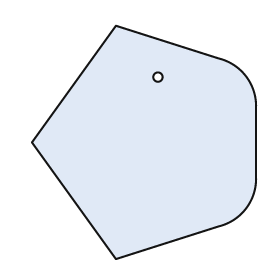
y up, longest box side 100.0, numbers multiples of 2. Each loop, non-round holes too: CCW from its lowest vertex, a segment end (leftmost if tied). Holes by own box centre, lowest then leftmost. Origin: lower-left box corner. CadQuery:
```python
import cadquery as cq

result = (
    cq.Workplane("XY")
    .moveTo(36.0, 0.0)
    .lineTo(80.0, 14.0)
    .threePointArc((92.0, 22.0), (96.0, 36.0))
    .lineTo(96.0, 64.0)
    .threePointArc((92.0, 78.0), (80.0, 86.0))
    .lineTo(36.0, 100.0)
    .lineTo(0.0, 50.0)
    .close()
    .moveTo(54.0, 78.0)
    .circle(2.0)
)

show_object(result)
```